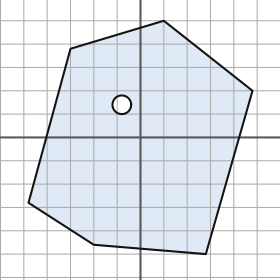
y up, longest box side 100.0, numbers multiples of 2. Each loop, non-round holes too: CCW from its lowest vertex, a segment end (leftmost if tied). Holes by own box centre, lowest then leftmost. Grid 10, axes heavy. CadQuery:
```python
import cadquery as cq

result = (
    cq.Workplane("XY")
    .moveTo(28.0, -50.0)
    .lineTo(48.0, 20.0)
    .lineTo(10.0, 50.0)
    .lineTo(-30.0, 38.0)
    .lineTo(-48.0, -28.0)
    .lineTo(-20.0, -46.0)
    .close()
    .moveTo(-8.0, 14.0)
    .circle(4.0)
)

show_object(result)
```